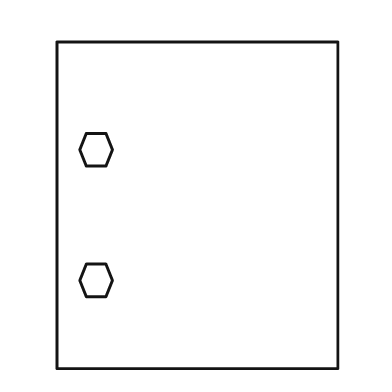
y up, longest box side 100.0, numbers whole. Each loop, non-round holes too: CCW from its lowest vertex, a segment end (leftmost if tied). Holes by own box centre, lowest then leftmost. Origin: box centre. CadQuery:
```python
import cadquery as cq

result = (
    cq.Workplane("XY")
    .moveTo(-43.0, -50.0)
    .lineTo(43.0, -50.0)
    .lineTo(43.0, 50.0)
    .lineTo(-43.0, 50.0)
    .close()
    .moveTo(-34.0, -28.0)
    .lineTo(-28.0, -28.0)
    .lineTo(-26.0, -23.0)
    .lineTo(-28.0, -18.0)
    .lineTo(-34.0, -18.0)
    .lineTo(-36.0, -23.0)
    .close()
    .moveTo(-34.0, 12.0)
    .lineTo(-28.0, 12.0)
    .lineTo(-26.0, 17.0)
    .lineTo(-28.0, 22.0)
    .lineTo(-34.0, 22.0)
    .lineTo(-36.0, 17.0)
    .close()
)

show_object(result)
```